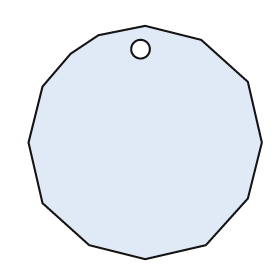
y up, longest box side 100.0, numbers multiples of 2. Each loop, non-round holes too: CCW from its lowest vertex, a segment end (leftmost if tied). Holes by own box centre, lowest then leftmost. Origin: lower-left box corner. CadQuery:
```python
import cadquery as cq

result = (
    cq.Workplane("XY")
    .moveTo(50.0, 0.0)
    .lineTo(76.0, 6.0)
    .lineTo(94.0, 26.0)
    .lineTo(100.0, 50.0)
    .lineTo(94.0, 76.0)
    .lineTo(74.0, 94.0)
    .lineTo(50.0, 100.0)
    .lineTo(30.0, 96.0)
    .lineTo(18.0, 88.0)
    .lineTo(6.0, 74.0)
    .lineTo(0.0, 50.0)
    .lineTo(6.0, 24.0)
    .lineTo(26.0, 6.0)
    .close()
    .moveTo(48.0, 90.0)
    .circle(4.0)
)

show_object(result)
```